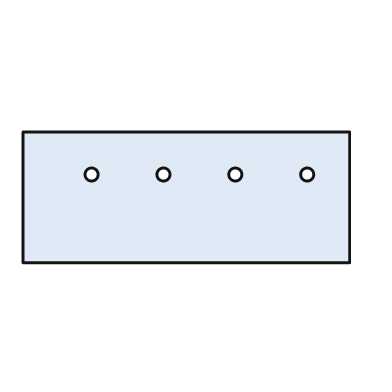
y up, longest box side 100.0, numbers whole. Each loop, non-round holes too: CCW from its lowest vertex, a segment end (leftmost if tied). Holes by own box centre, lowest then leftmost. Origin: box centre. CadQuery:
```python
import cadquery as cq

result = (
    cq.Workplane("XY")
    .moveTo(-50.0, -20.0)
    .lineTo(50.0, -20.0)
    .lineTo(50.0, 20.0)
    .lineTo(-50.0, 20.0)
    .close()
    .moveTo(-29.0, 7.0)
    .circle(2.0)
    .moveTo(-7.0, 7.0)
    .circle(2.0)
    .moveTo(15.0, 7.0)
    .circle(2.0)
    .moveTo(37.0, 7.0)
    .circle(2.0)
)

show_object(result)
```